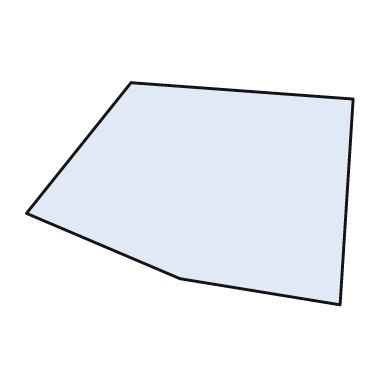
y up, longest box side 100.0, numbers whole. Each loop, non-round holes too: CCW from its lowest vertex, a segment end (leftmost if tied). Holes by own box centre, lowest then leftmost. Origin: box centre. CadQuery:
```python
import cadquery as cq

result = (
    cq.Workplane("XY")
    .moveTo(46.0, -34.0)
    .lineTo(50.0, 29.0)
    .lineTo(-18.0, 34.0)
    .lineTo(-50.0, -6.0)
    .lineTo(-3.0, -26.0)
    .close()
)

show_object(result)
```